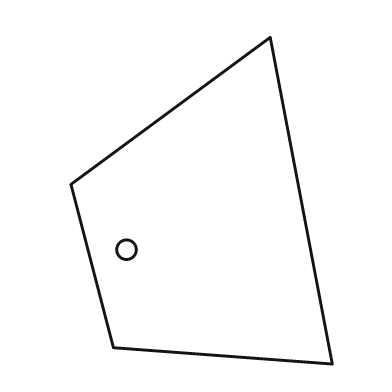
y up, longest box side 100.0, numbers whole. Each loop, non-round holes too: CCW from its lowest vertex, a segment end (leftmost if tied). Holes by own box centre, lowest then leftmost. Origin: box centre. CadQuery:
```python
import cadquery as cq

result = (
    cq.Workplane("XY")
    .moveTo(40.0, -50.0)
    .lineTo(21.0, 50.0)
    .lineTo(-40.0, 5.0)
    .lineTo(-27.0, -45.0)
    .close()
    .moveTo(-23.0, -15.0)
    .circle(3.0)
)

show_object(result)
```